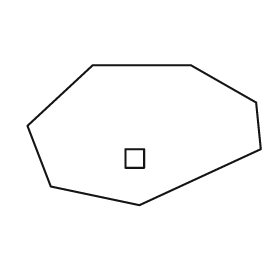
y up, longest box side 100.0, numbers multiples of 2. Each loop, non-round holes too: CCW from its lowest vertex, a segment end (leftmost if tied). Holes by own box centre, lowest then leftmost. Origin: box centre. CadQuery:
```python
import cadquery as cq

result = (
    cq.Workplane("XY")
    .moveTo(-2.0, -30.0)
    .lineTo(50.0, -6.0)
    .lineTo(48.0, 14.0)
    .lineTo(20.0, 30.0)
    .lineTo(-22.0, 30.0)
    .lineTo(-50.0, 4.0)
    .lineTo(-40.0, -22.0)
    .close()
    .moveTo(-8.0, -14.0)
    .lineTo(0.0, -14.0)
    .lineTo(0.0, -6.0)
    .lineTo(-8.0, -6.0)
    .close()
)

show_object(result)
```